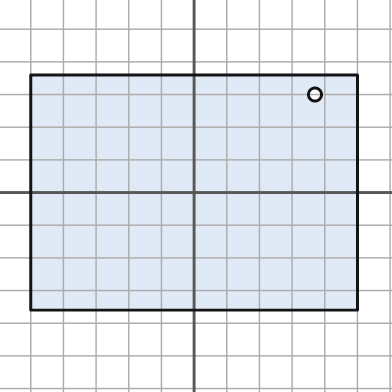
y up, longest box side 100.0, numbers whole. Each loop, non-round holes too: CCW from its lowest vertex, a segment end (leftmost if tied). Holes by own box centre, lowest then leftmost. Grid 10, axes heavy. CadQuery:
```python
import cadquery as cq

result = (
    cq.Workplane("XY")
    .moveTo(-50.0, -36.0)
    .lineTo(50.0, -36.0)
    .lineTo(50.0, 36.0)
    .lineTo(-50.0, 36.0)
    .close()
    .moveTo(37.0, 30.0)
    .circle(2.0)
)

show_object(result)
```